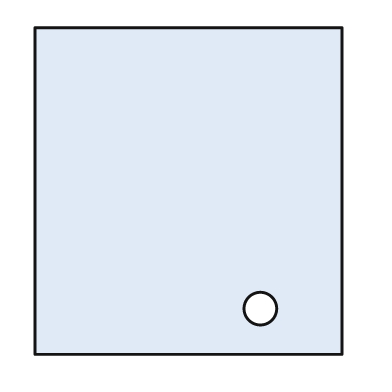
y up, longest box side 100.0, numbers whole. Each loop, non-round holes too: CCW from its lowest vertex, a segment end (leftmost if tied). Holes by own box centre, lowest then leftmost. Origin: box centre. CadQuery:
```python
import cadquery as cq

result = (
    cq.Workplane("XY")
    .moveTo(-47.0, -50.0)
    .lineTo(47.0, -50.0)
    .lineTo(47.0, 50.0)
    .lineTo(-47.0, 50.0)
    .close()
    .moveTo(22.0, -36.0)
    .circle(5.0)
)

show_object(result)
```